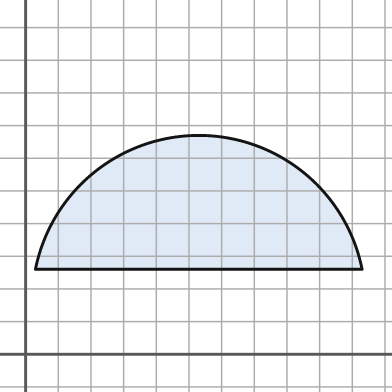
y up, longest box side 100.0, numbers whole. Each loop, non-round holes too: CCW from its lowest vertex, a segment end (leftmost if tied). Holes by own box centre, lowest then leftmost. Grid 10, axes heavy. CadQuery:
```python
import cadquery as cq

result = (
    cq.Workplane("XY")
    .moveTo(3.0, 26.0)
    .lineTo(103.0, 26.0)
    .threePointArc((53.0, 67.0), (3.0, 26.0))
    .close()
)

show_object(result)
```